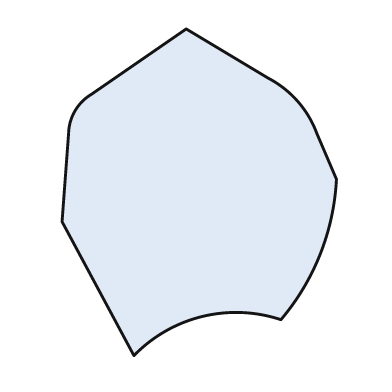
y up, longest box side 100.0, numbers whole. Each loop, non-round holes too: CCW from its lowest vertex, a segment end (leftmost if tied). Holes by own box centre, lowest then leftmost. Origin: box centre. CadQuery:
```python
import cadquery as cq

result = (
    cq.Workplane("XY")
    .moveTo(-20.0, -50.0)
    .threePointArc((1.0, -38.0), (25.0, -39.0))
    .threePointArc((37.0, -19.0), (42.0, 4.0))
    .lineTo(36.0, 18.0)
    .threePointArc((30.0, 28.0), (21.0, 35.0))
    .lineTo(-4.0, 50.0)
    .lineTo(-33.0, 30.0)
    .threePointArc((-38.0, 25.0), (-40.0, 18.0))
    .lineTo(-42.0, -9.0)
    .close()
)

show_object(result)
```